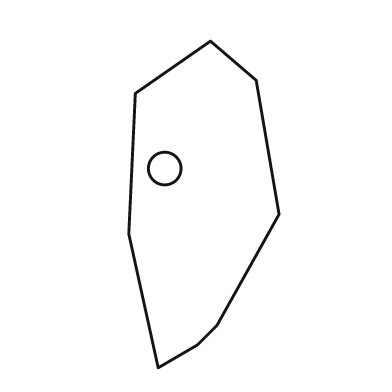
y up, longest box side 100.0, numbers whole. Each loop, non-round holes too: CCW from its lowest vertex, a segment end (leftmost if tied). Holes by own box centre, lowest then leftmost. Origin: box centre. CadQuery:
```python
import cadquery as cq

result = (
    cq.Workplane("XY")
    .moveTo(-14.0, -50.0)
    .lineTo(-2.0, -43.0)
    .lineTo(4.0, -37.0)
    .lineTo(23.0, -3.0)
    .lineTo(16.0, 38.0)
    .lineTo(2.0, 50.0)
    .lineTo(-21.0, 34.0)
    .lineTo(-23.0, -9.0)
    .close()
    .moveTo(-12.0, 11.0)
    .circle(5.0)
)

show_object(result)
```